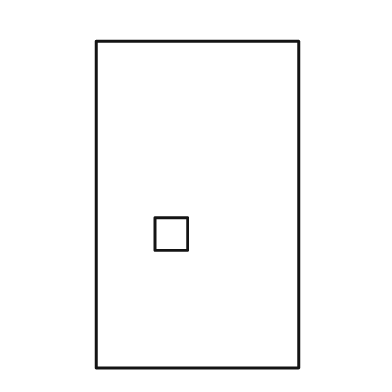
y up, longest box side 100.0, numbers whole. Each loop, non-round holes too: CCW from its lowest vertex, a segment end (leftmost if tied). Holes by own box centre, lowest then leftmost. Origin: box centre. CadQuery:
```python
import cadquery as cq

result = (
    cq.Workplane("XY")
    .moveTo(-31.0, -50.0)
    .lineTo(31.0, -50.0)
    .lineTo(31.0, 50.0)
    .lineTo(-31.0, 50.0)
    .close()
    .moveTo(-13.0, -14.0)
    .lineTo(-3.0, -14.0)
    .lineTo(-3.0, -4.0)
    .lineTo(-13.0, -4.0)
    .close()
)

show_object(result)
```